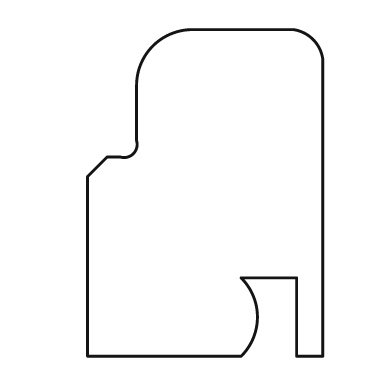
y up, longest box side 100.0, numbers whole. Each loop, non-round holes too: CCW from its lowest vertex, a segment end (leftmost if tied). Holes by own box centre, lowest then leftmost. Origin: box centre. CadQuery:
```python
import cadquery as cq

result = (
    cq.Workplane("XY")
    .moveTo(-36.0, -50.0)
    .lineTo(11.0, -50.0)
    .threePointArc((16.0, -38.0), (11.0, -26.0))
    .lineTo(28.0, -26.0)
    .lineTo(28.0, -50.0)
    .lineTo(36.0, -50.0)
    .lineTo(36.0, 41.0)
    .threePointArc((33.0, 47.0), (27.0, 50.0))
    .lineTo(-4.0, 50.0)
    .threePointArc((-16.0, 45.0), (-21.0, 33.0))
    .lineTo(-21.0, 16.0)
    .threePointArc((-22.0, 12.0), (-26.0, 11.0))
    .lineTo(-30.0, 11.0)
    .lineTo(-36.0, 5.0)
    .close()
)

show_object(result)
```